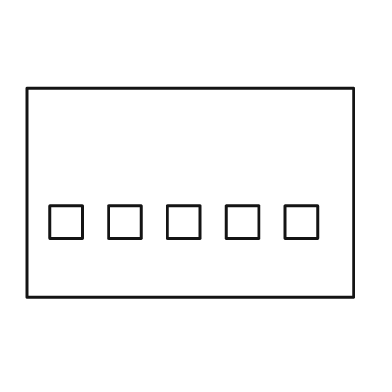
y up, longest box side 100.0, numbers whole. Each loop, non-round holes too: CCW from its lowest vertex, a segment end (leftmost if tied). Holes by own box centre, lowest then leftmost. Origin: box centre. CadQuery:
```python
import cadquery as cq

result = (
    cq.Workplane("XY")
    .moveTo(-50.0, -32.0)
    .lineTo(50.0, -32.0)
    .lineTo(50.0, 32.0)
    .lineTo(-50.0, 32.0)
    .close()
    .moveTo(-43.0, -14.0)
    .lineTo(-33.0, -14.0)
    .lineTo(-33.0, -4.0)
    .lineTo(-43.0, -4.0)
    .close()
    .moveTo(-25.0, -14.0)
    .lineTo(-15.0, -14.0)
    .lineTo(-15.0, -4.0)
    .lineTo(-25.0, -4.0)
    .close()
    .moveTo(-7.0, -14.0)
    .lineTo(3.0, -14.0)
    .lineTo(3.0, -4.0)
    .lineTo(-7.0, -4.0)
    .close()
    .moveTo(11.0, -14.0)
    .lineTo(21.0, -14.0)
    .lineTo(21.0, -4.0)
    .lineTo(11.0, -4.0)
    .close()
    .moveTo(29.0, -14.0)
    .lineTo(39.0, -14.0)
    .lineTo(39.0, -4.0)
    .lineTo(29.0, -4.0)
    .close()
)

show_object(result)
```